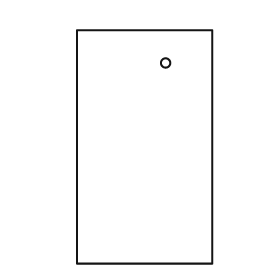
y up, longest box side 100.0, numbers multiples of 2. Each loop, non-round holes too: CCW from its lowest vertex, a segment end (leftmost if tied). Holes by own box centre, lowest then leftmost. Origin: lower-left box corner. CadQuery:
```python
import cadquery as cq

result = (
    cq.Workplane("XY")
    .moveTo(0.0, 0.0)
    .lineTo(58.0, 0.0)
    .lineTo(58.0, 100.0)
    .lineTo(0.0, 100.0)
    .close()
    .moveTo(38.0, 86.0)
    .circle(2.0)
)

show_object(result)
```